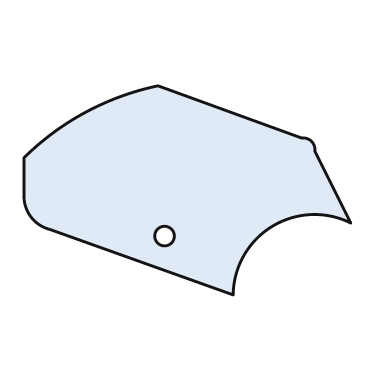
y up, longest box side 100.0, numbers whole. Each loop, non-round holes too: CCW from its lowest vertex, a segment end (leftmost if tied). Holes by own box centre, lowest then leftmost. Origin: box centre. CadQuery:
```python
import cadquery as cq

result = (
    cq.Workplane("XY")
    .moveTo(14.0, -32.0)
    .threePointArc((26.0, -11.0), (50.0, -10.0))
    .lineTo(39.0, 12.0)
    .threePointArc((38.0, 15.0), (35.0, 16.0))
    .lineTo(-9.0, 32.0)
    .threePointArc((-31.0, 24.0), (-50.0, 10.0))
    .lineTo(-50.0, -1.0)
    .threePointArc((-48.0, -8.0), (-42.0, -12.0))
    .close()
    .moveTo(-7.0, -14.0)
    .circle(3.0)
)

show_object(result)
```